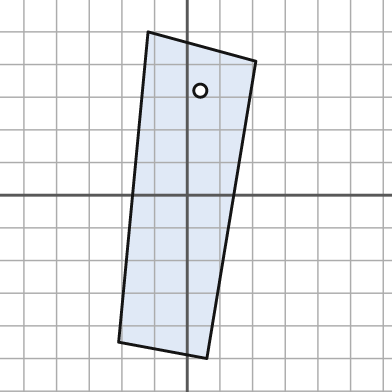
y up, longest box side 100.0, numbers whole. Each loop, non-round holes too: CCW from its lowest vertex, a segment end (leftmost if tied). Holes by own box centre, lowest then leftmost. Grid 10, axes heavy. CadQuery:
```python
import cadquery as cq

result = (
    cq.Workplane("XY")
    .moveTo(6.0, -50.0)
    .lineTo(21.0, 41.0)
    .lineTo(-12.0, 50.0)
    .lineTo(-21.0, -45.0)
    .close()
    .moveTo(4.0, 32.0)
    .circle(2.0)
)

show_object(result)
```